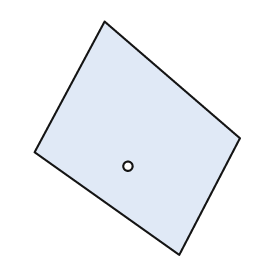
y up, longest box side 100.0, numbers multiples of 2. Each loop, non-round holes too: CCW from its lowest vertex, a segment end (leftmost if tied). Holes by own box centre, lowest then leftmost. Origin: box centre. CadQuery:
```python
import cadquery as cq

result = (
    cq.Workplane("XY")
    .moveTo(18.0, -50.0)
    .lineTo(44.0, 0.0)
    .lineTo(-14.0, 50.0)
    .lineTo(-44.0, -6.0)
    .close()
    .moveTo(-4.0, -12.0)
    .circle(2.0)
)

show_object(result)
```